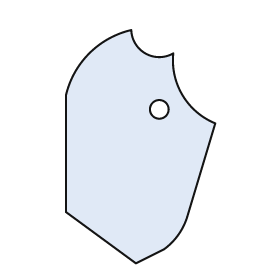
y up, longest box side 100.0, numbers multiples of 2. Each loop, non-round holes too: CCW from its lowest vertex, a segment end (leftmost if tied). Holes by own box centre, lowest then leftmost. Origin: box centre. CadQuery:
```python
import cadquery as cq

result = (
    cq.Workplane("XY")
    .moveTo(-2.0, -50.0)
    .lineTo(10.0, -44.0)
    .threePointArc((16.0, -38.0), (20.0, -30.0))
    .lineTo(32.0, 10.0)
    .threePointArc((18.0, 22.0), (14.0, 40.0))
    .threePointArc((2.0, 40.0), (-4.0, 50.0))
    .threePointArc((-22.0, 40.0), (-32.0, 22.0))
    .lineTo(-32.0, -28.0)
    .close()
    .moveTo(8.0, 16.0)
    .circle(4.0)
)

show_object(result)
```